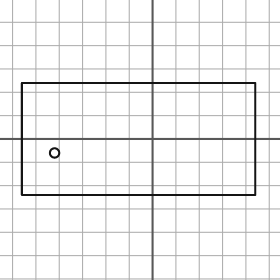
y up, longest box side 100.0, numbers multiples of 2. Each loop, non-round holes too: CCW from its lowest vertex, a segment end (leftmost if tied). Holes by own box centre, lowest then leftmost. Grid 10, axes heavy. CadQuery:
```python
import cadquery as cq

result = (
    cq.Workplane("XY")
    .moveTo(-56.0, -24.0)
    .lineTo(44.0, -24.0)
    .lineTo(44.0, 24.0)
    .lineTo(-56.0, 24.0)
    .close()
    .moveTo(-42.0, -6.0)
    .circle(2.0)
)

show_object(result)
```